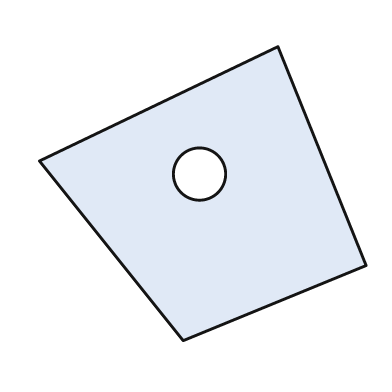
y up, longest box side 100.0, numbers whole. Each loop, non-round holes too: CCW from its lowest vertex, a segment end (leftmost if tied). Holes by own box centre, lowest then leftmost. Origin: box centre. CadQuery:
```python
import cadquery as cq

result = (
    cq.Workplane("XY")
    .moveTo(-6.0, -45.0)
    .lineTo(50.0, -22.0)
    .lineTo(23.0, 45.0)
    .lineTo(-50.0, 10.0)
    .close()
    .moveTo(-1.0, 6.0)
    .circle(8.0)
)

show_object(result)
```